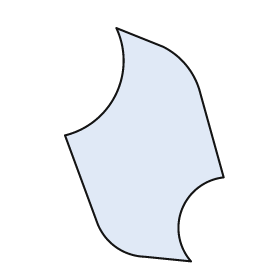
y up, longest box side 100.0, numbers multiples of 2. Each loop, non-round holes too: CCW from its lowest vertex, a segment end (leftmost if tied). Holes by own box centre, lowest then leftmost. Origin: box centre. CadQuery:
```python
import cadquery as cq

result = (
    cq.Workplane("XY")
    .moveTo(20.0, -50.0)
    .threePointArc((16.0, -28.0), (34.0, -14.0))
    .lineTo(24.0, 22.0)
    .threePointArc((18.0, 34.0), (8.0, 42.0))
    .lineTo(-12.0, 50.0)
    .threePointArc((-12.0, 22.0), (-34.0, 4.0))
    .lineTo(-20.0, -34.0)
    .threePointArc((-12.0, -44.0), (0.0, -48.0))
    .close()
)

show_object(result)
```